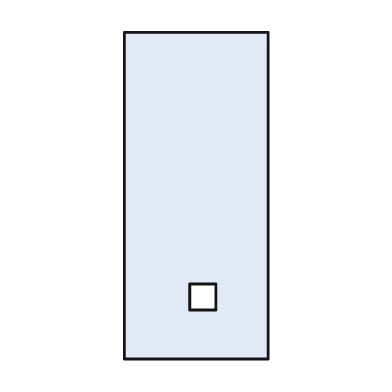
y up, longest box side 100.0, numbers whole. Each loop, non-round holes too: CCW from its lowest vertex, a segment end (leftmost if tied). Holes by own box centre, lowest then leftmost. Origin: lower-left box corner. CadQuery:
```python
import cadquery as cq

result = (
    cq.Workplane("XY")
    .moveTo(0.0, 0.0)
    .lineTo(44.0, 0.0)
    .lineTo(44.0, 100.0)
    .lineTo(0.0, 100.0)
    .close()
    .moveTo(20.0, 15.0)
    .lineTo(28.0, 15.0)
    .lineTo(28.0, 23.0)
    .lineTo(20.0, 23.0)
    .close()
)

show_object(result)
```